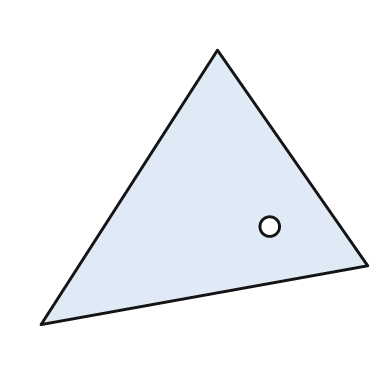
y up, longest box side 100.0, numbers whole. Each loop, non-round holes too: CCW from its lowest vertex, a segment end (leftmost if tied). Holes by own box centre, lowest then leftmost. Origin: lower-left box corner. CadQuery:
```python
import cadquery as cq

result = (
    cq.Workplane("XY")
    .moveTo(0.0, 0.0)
    .lineTo(100.0, 18.0)
    .lineTo(54.0, 84.0)
    .close()
    .moveTo(70.0, 30.0)
    .circle(3.0)
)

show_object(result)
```